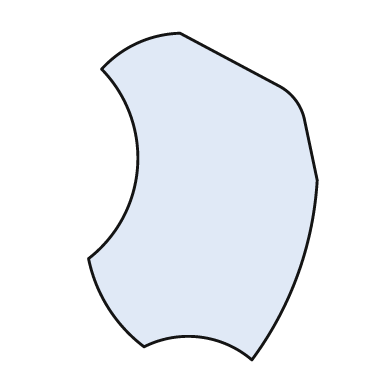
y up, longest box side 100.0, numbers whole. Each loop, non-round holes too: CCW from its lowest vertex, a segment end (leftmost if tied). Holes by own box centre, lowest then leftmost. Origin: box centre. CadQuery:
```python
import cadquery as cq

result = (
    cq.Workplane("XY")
    .moveTo(15.0, -50.0)
    .threePointArc((29.0, -24.0), (35.0, 5.0))
    .lineTo(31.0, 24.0)
    .threePointArc((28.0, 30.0), (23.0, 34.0))
    .lineTo(-7.0, 50.0)
    .threePointArc((-20.0, 47.0), (-31.0, 39.0))
    .threePointArc((-20.0, 9.0), (-35.0, -19.0))
    .threePointArc((-29.0, -34.0), (-18.0, -46.0))
    .threePointArc((-1.0, -43.0), (15.0, -50.0))
    .close()
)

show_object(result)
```